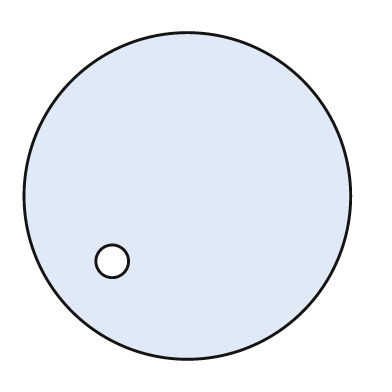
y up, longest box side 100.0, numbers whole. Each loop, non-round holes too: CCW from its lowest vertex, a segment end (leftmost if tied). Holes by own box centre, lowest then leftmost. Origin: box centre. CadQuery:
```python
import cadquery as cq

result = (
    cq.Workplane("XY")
    .moveTo(0.0, 0.0)
    .circle(50.0)
    .moveTo(-23.0, -20.0)
    .circle(5.0)
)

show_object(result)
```